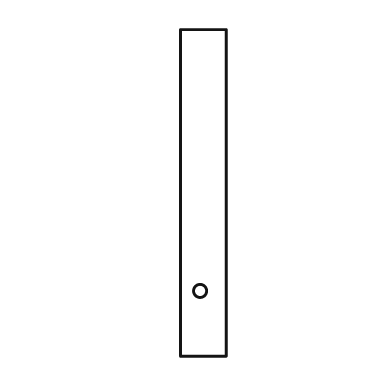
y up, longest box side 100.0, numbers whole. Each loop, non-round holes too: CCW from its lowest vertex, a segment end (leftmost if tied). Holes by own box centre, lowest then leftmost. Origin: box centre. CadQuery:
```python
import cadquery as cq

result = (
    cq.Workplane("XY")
    .moveTo(-7.0, -50.0)
    .lineTo(7.0, -50.0)
    .lineTo(7.0, 50.0)
    .lineTo(-7.0, 50.0)
    .close()
    .moveTo(-1.0, -30.0)
    .circle(2.0)
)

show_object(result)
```